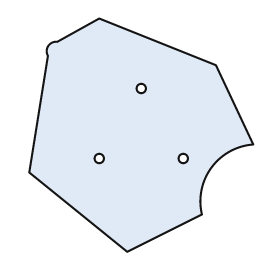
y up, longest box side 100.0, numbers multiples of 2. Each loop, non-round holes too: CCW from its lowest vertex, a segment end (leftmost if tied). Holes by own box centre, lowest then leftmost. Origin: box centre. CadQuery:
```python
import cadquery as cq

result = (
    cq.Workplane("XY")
    .moveTo(-6.0, -50.0)
    .lineTo(26.0, -34.0)
    .threePointArc((30.0, -14.0), (48.0, -4.0))
    .lineTo(32.0, 30.0)
    .lineTo(-18.0, 50.0)
    .lineTo(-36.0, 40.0)
    .threePointArc((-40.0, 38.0), (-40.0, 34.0))
    .lineTo(-48.0, -16.0)
    .close()
    .moveTo(-18.0, -10.0)
    .circle(2.0)
    .moveTo(18.0, -10.0)
    .circle(2.0)
    .moveTo(0.0, 20.0)
    .circle(2.0)
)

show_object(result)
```